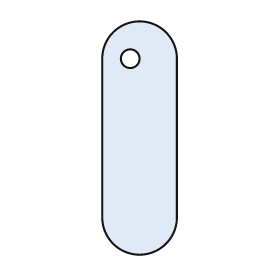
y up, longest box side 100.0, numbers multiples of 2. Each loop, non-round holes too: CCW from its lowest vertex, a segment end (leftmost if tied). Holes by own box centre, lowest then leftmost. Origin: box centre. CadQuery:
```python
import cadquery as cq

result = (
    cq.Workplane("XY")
    .moveTo(-16.0, -34.0)
    .threePointArc((0.0, -50.0), (16.0, -34.0))
    .lineTo(16.0, 34.0)
    .threePointArc((0.0, 50.0), (-16.0, 34.0))
    .close()
    .moveTo(-4.0, 34.0)
    .circle(4.0)
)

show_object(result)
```